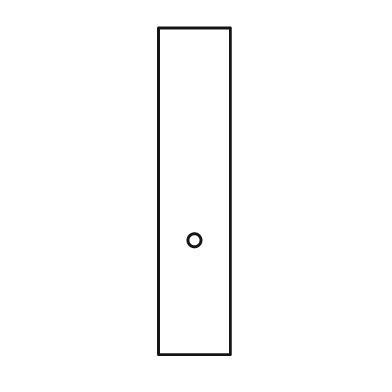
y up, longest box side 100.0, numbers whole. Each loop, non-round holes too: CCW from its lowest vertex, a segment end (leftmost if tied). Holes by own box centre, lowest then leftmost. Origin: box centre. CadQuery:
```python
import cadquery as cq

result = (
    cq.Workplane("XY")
    .moveTo(-11.0, -50.0)
    .lineTo(11.0, -50.0)
    .lineTo(11.0, 50.0)
    .lineTo(-11.0, 50.0)
    .close()
    .moveTo(0.0, -15.0)
    .circle(2.0)
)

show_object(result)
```